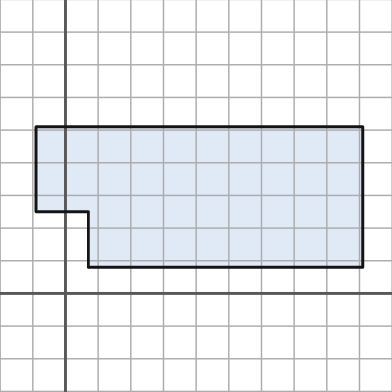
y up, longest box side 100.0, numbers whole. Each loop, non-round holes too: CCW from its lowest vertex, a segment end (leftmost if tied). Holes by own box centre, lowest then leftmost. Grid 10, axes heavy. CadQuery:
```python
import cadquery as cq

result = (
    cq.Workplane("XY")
    .moveTo(7.0, 8.0)
    .lineTo(91.0, 8.0)
    .lineTo(91.0, 51.0)
    .lineTo(-9.0, 51.0)
    .lineTo(-9.0, 25.0)
    .lineTo(7.0, 25.0)
    .close()
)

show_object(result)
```